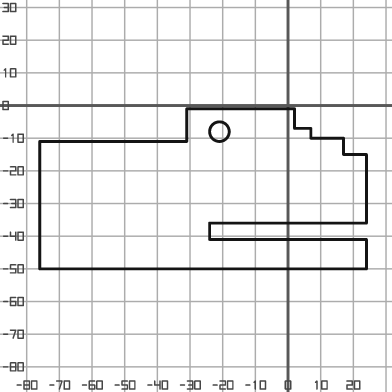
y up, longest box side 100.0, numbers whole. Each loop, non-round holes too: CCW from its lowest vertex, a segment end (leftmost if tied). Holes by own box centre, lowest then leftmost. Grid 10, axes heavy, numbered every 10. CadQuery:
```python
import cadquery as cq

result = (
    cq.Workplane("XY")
    .moveTo(-76.0, -50.0)
    .lineTo(24.0, -50.0)
    .lineTo(24.0, -41.0)
    .lineTo(-24.0, -41.0)
    .lineTo(-24.0, -36.0)
    .lineTo(24.0, -36.0)
    .lineTo(24.0, -15.0)
    .lineTo(17.0, -15.0)
    .lineTo(17.0, -10.0)
    .lineTo(7.0, -10.0)
    .lineTo(7.0, -7.0)
    .lineTo(2.0, -7.0)
    .lineTo(2.0, -1.0)
    .lineTo(-31.0, -1.0)
    .lineTo(-31.0, -11.0)
    .lineTo(-76.0, -11.0)
    .close()
    .moveTo(-21.0, -8.0)
    .circle(3.0)
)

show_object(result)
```